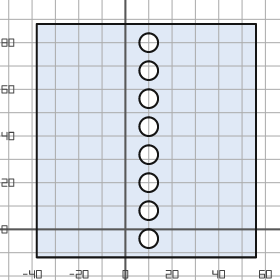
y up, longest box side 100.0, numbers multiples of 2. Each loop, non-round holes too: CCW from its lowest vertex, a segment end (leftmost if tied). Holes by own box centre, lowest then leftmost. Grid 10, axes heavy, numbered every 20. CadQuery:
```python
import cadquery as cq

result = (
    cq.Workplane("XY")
    .moveTo(-38.0, -12.0)
    .lineTo(56.0, -12.0)
    .lineTo(56.0, 88.0)
    .lineTo(-38.0, 88.0)
    .close()
    .moveTo(10.0, -4.0)
    .circle(4.0)
    .moveTo(10.0, 8.0)
    .circle(4.0)
    .moveTo(10.0, 20.0)
    .circle(4.0)
    .moveTo(10.0, 32.0)
    .circle(4.0)
    .moveTo(10.0, 44.0)
    .circle(4.0)
    .moveTo(10.0, 56.0)
    .circle(4.0)
    .moveTo(10.0, 68.0)
    .circle(4.0)
    .moveTo(10.0, 80.0)
    .circle(4.0)
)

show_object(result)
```